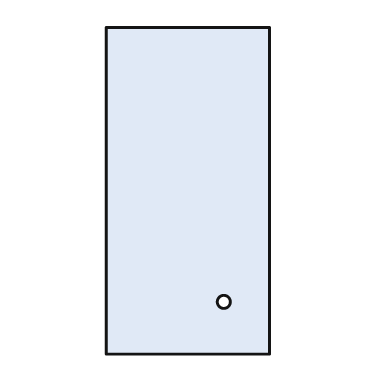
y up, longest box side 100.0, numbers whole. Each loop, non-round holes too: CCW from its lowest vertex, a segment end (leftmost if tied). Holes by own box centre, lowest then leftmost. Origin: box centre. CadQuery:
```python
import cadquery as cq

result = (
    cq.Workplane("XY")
    .moveTo(-25.0, -50.0)
    .lineTo(25.0, -50.0)
    .lineTo(25.0, 50.0)
    .lineTo(-25.0, 50.0)
    .close()
    .moveTo(11.0, -34.0)
    .circle(2.0)
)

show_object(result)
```